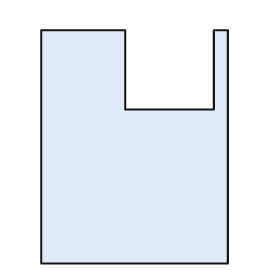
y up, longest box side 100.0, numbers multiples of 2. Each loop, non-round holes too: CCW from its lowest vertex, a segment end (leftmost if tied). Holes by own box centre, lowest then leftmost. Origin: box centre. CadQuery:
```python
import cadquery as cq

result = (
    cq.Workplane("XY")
    .moveTo(-40.0, -50.0)
    .lineTo(40.0, -50.0)
    .lineTo(40.0, 50.0)
    .lineTo(34.0, 50.0)
    .lineTo(34.0, 16.0)
    .lineTo(-4.0, 16.0)
    .lineTo(-4.0, 50.0)
    .lineTo(-40.0, 50.0)
    .close()
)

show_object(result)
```